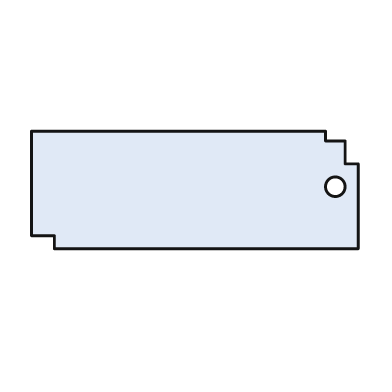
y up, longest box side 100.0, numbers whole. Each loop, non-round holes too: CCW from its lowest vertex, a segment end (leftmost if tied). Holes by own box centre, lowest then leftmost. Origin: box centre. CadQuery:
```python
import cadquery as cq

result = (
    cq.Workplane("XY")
    .moveTo(-43.0, -18.0)
    .lineTo(50.0, -18.0)
    .lineTo(50.0, 8.0)
    .lineTo(46.0, 8.0)
    .lineTo(46.0, 15.0)
    .lineTo(40.0, 15.0)
    .lineTo(40.0, 18.0)
    .lineTo(-50.0, 18.0)
    .lineTo(-50.0, -14.0)
    .lineTo(-43.0, -14.0)
    .close()
    .moveTo(43.0, 1.0)
    .circle(3.0)
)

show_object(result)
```